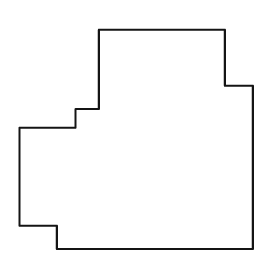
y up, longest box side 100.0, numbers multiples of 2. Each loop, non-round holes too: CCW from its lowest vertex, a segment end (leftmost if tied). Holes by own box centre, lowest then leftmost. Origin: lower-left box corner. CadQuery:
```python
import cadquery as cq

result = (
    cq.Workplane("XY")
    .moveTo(16.0, 0.0)
    .lineTo(100.0, 0.0)
    .lineTo(100.0, 70.0)
    .lineTo(88.0, 70.0)
    .lineTo(88.0, 94.0)
    .lineTo(34.0, 94.0)
    .lineTo(34.0, 60.0)
    .lineTo(24.0, 60.0)
    .lineTo(24.0, 52.0)
    .lineTo(0.0, 52.0)
    .lineTo(0.0, 10.0)
    .lineTo(16.0, 10.0)
    .close()
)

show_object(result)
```